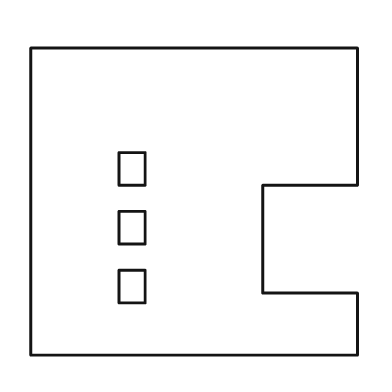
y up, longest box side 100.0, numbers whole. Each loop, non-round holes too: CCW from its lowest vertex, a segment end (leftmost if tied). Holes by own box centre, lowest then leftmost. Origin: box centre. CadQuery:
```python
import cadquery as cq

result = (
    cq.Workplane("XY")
    .moveTo(-50.0, -47.0)
    .lineTo(50.0, -47.0)
    .lineTo(50.0, -28.0)
    .lineTo(21.0, -28.0)
    .lineTo(21.0, 5.0)
    .lineTo(50.0, 5.0)
    .lineTo(50.0, 47.0)
    .lineTo(-50.0, 47.0)
    .close()
    .moveTo(-23.0, -31.0)
    .lineTo(-15.0, -31.0)
    .lineTo(-15.0, -21.0)
    .lineTo(-23.0, -21.0)
    .close()
    .moveTo(-23.0, -13.0)
    .lineTo(-15.0, -13.0)
    .lineTo(-15.0, -3.0)
    .lineTo(-23.0, -3.0)
    .close()
    .moveTo(-23.0, 5.0)
    .lineTo(-15.0, 5.0)
    .lineTo(-15.0, 15.0)
    .lineTo(-23.0, 15.0)
    .close()
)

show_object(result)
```